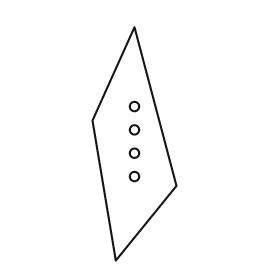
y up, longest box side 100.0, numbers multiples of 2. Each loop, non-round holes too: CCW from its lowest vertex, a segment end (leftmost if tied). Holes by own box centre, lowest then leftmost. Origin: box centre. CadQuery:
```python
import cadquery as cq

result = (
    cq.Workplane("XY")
    .moveTo(-8.0, -50.0)
    .lineTo(18.0, -18.0)
    .lineTo(0.0, 50.0)
    .lineTo(-18.0, 10.0)
    .close()
    .moveTo(0.0, -14.0)
    .circle(2.0)
    .moveTo(0.0, -4.0)
    .circle(2.0)
    .moveTo(0.0, 6.0)
    .circle(2.0)
    .moveTo(0.0, 16.0)
    .circle(2.0)
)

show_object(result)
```